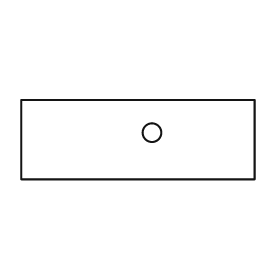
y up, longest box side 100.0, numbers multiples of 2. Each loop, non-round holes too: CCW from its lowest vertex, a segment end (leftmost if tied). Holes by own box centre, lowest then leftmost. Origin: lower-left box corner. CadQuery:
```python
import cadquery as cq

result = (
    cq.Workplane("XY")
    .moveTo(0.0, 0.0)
    .lineTo(100.0, 0.0)
    .lineTo(100.0, 34.0)
    .lineTo(0.0, 34.0)
    .close()
    .moveTo(56.0, 20.0)
    .circle(4.0)
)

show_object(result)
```